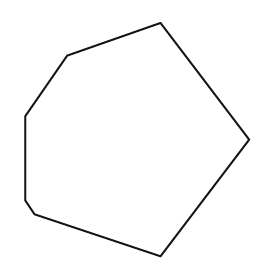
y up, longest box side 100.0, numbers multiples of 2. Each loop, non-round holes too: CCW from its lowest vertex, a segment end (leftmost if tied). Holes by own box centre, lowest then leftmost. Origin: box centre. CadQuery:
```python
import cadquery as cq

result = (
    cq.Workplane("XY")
    .moveTo(10.0, -50.0)
    .lineTo(48.0, 0.0)
    .lineTo(10.0, 50.0)
    .lineTo(-30.0, 36.0)
    .lineTo(-48.0, 10.0)
    .lineTo(-48.0, -26.0)
    .lineTo(-44.0, -32.0)
    .close()
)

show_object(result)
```